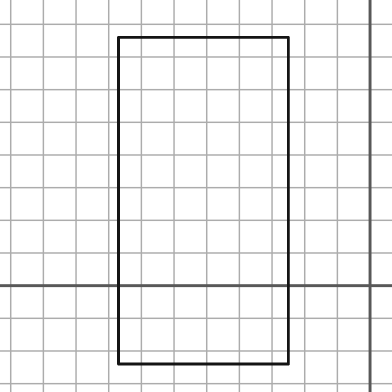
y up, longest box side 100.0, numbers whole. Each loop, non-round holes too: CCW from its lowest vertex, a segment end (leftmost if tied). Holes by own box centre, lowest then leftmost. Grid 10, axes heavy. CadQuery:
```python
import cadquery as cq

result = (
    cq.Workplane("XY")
    .moveTo(-77.0, -24.0)
    .lineTo(-25.0, -24.0)
    .lineTo(-25.0, 76.0)
    .lineTo(-77.0, 76.0)
    .close()
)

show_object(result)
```